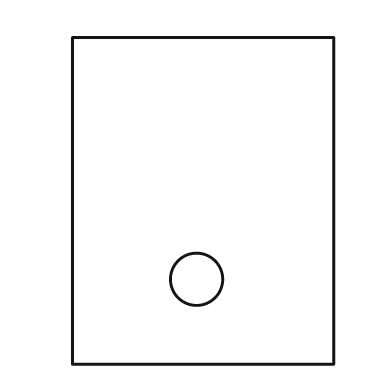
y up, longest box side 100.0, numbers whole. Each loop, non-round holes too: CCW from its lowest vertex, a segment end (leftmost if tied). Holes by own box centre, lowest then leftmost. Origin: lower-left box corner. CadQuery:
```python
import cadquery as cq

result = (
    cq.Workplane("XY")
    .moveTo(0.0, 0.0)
    .lineTo(80.0, 0.0)
    .lineTo(80.0, 100.0)
    .lineTo(0.0, 100.0)
    .close()
    .moveTo(38.0, 26.0)
    .circle(8.0)
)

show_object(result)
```